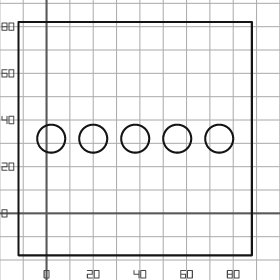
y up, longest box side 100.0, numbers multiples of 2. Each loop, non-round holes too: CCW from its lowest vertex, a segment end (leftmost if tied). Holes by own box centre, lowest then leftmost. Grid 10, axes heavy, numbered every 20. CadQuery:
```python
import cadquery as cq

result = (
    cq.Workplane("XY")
    .moveTo(-12.0, -18.0)
    .lineTo(88.0, -18.0)
    .lineTo(88.0, 82.0)
    .lineTo(-12.0, 82.0)
    .close()
    .moveTo(2.0, 32.0)
    .circle(6.0)
    .moveTo(20.0, 32.0)
    .circle(6.0)
    .moveTo(38.0, 32.0)
    .circle(6.0)
    .moveTo(56.0, 32.0)
    .circle(6.0)
    .moveTo(74.0, 32.0)
    .circle(6.0)
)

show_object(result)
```